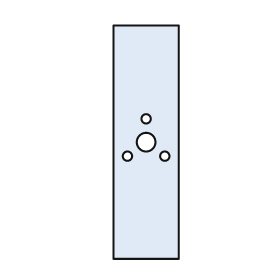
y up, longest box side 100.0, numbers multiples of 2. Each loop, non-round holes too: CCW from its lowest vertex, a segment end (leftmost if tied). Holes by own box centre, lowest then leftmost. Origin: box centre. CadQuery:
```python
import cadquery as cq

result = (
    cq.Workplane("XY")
    .moveTo(-14.0, -50.0)
    .lineTo(14.0, -50.0)
    .lineTo(14.0, 50.0)
    .lineTo(-14.0, 50.0)
    .close()
    .moveTo(-8.0, -6.0)
    .circle(2.0)
    .moveTo(8.0, -6.0)
    .circle(2.0)
    .moveTo(0.0, 0.0)
    .circle(4.0)
    .moveTo(0.0, 10.0)
    .circle(2.0)
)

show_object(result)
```